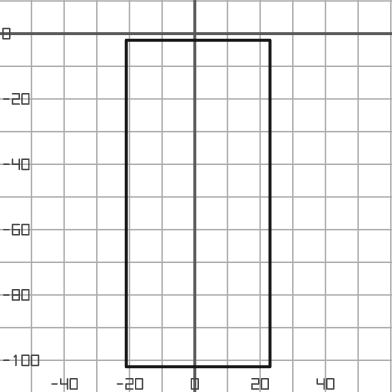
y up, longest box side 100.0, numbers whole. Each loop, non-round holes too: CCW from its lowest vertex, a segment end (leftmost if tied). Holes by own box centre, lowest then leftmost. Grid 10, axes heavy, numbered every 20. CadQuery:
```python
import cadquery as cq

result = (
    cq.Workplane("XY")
    .moveTo(-21.0, -102.0)
    .lineTo(23.0, -102.0)
    .lineTo(23.0, -2.0)
    .lineTo(-21.0, -2.0)
    .close()
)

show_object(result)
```